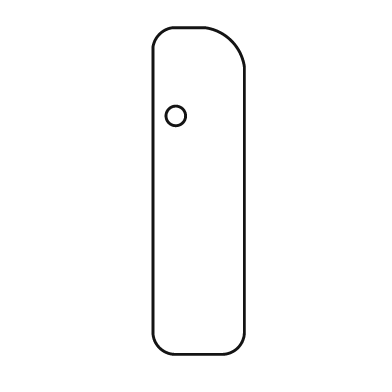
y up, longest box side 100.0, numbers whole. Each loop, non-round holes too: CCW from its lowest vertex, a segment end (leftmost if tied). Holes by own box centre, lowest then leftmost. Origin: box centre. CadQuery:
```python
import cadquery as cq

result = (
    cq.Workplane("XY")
    .moveTo(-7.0, -50.0)
    .lineTo(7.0, -50.0)
    .threePointArc((12.0, -48.0), (14.0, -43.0))
    .lineTo(14.0, 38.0)
    .threePointArc((10.0, 46.0), (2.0, 50.0))
    .lineTo(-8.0, 50.0)
    .threePointArc((-12.0, 48.0), (-14.0, 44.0))
    .lineTo(-14.0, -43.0)
    .threePointArc((-12.0, -48.0), (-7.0, -50.0))
    .close()
    .moveTo(-7.0, 23.0)
    .circle(3.0)
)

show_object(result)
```